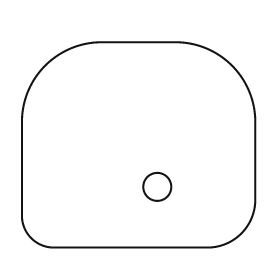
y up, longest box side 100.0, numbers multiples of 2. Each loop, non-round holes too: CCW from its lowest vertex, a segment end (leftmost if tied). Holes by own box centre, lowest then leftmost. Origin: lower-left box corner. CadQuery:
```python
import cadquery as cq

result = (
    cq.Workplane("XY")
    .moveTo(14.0, 0.0)
    .lineTo(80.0, 0.0)
    .threePointArc((94.0, 6.0), (100.0, 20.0))
    .lineTo(100.0, 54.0)
    .threePointArc((90.0, 78.0), (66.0, 88.0))
    .lineTo(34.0, 88.0)
    .threePointArc((10.0, 78.0), (0.0, 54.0))
    .lineTo(0.0, 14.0)
    .threePointArc((4.0, 4.0), (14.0, 0.0))
    .close()
    .moveTo(58.0, 26.0)
    .circle(6.0)
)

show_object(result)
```